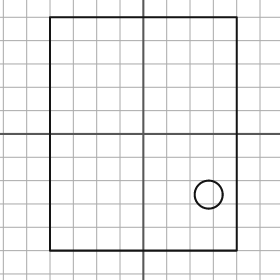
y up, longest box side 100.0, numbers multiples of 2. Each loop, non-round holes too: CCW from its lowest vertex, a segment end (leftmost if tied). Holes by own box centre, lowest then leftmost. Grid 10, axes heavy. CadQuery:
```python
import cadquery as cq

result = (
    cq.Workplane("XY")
    .moveTo(-40.0, -50.0)
    .lineTo(40.0, -50.0)
    .lineTo(40.0, 50.0)
    .lineTo(-40.0, 50.0)
    .close()
    .moveTo(28.0, -26.0)
    .circle(6.0)
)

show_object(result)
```